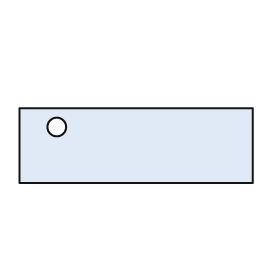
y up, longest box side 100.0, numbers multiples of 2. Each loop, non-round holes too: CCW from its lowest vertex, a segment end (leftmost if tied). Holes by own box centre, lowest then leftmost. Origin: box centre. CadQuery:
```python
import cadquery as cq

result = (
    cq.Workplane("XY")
    .moveTo(-50.0, -16.0)
    .lineTo(50.0, -16.0)
    .lineTo(50.0, 16.0)
    .lineTo(-50.0, 16.0)
    .close()
    .moveTo(-34.0, 8.0)
    .circle(4.0)
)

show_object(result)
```